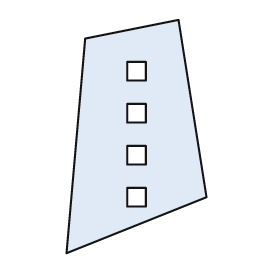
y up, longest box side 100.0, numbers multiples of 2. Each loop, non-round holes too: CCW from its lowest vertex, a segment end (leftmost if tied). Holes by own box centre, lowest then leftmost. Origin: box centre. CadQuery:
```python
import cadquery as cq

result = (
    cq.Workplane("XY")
    .moveTo(-30.0, -50.0)
    .lineTo(30.0, -26.0)
    .lineTo(18.0, 50.0)
    .lineTo(-22.0, 42.0)
    .close()
    .moveTo(-4.0, -30.0)
    .lineTo(4.0, -30.0)
    .lineTo(4.0, -22.0)
    .lineTo(-4.0, -22.0)
    .close()
    .moveTo(-4.0, -12.0)
    .lineTo(4.0, -12.0)
    .lineTo(4.0, -4.0)
    .lineTo(-4.0, -4.0)
    .close()
    .moveTo(-4.0, 6.0)
    .lineTo(4.0, 6.0)
    .lineTo(4.0, 14.0)
    .lineTo(-4.0, 14.0)
    .close()
    .moveTo(-4.0, 24.0)
    .lineTo(4.0, 24.0)
    .lineTo(4.0, 32.0)
    .lineTo(-4.0, 32.0)
    .close()
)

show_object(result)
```